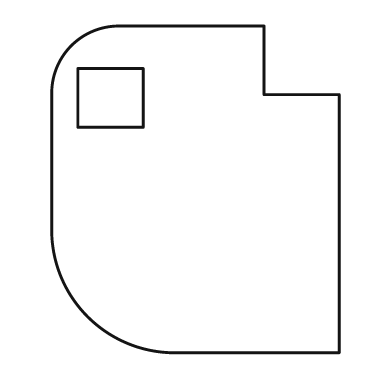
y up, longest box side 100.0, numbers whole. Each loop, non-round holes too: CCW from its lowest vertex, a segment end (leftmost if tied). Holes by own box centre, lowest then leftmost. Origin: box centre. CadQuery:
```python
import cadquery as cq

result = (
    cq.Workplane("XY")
    .moveTo(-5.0, -50.0)
    .lineTo(44.0, -50.0)
    .lineTo(44.0, 29.0)
    .lineTo(21.0, 29.0)
    .lineTo(21.0, 50.0)
    .lineTo(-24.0, 50.0)
    .threePointArc((-38.0, 44.0), (-44.0, 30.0))
    .lineTo(-44.0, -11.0)
    .threePointArc((-33.0, -39.0), (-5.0, -50.0))
    .close()
    .moveTo(-36.0, 19.0)
    .lineTo(-16.0, 19.0)
    .lineTo(-16.0, 37.0)
    .lineTo(-36.0, 37.0)
    .close()
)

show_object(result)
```